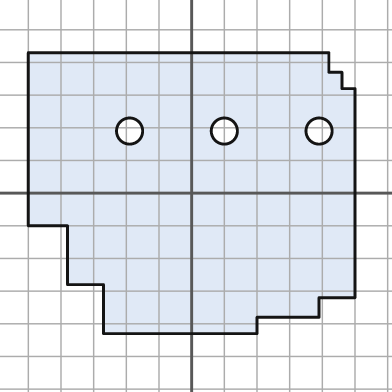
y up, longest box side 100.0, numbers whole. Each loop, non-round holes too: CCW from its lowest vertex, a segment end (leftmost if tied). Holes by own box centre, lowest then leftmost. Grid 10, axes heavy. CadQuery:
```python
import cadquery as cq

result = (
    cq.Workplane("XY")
    .moveTo(-27.0, -43.0)
    .lineTo(20.0, -43.0)
    .lineTo(20.0, -38.0)
    .lineTo(39.0, -38.0)
    .lineTo(39.0, -32.0)
    .lineTo(50.0, -32.0)
    .lineTo(50.0, 32.0)
    .lineTo(46.0, 32.0)
    .lineTo(46.0, 37.0)
    .lineTo(42.0, 37.0)
    .lineTo(42.0, 43.0)
    .lineTo(-50.0, 43.0)
    .lineTo(-50.0, -10.0)
    .lineTo(-38.0, -10.0)
    .lineTo(-38.0, -28.0)
    .lineTo(-27.0, -28.0)
    .close()
    .moveTo(-19.0, 19.0)
    .circle(4.0)
    .moveTo(10.0, 19.0)
    .circle(4.0)
    .moveTo(39.0, 19.0)
    .circle(4.0)
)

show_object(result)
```